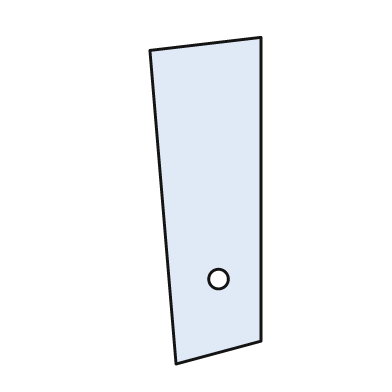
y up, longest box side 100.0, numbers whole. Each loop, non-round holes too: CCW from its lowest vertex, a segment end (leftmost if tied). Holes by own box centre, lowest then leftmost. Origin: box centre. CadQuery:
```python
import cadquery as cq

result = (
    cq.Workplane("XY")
    .moveTo(-9.0, -50.0)
    .lineTo(17.0, -43.0)
    .lineTo(17.0, 50.0)
    .lineTo(-17.0, 46.0)
    .close()
    .moveTo(4.0, -24.0)
    .circle(3.0)
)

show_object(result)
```